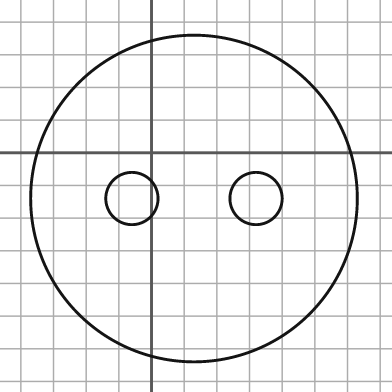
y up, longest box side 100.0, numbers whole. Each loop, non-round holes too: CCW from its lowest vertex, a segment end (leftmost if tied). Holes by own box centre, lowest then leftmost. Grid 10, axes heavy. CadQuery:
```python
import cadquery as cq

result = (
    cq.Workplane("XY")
    .moveTo(13.0, -14.0)
    .circle(50.0)
    .moveTo(-6.0, -14.0)
    .circle(8.0)
    .moveTo(32.0, -14.0)
    .circle(8.0)
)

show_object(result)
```